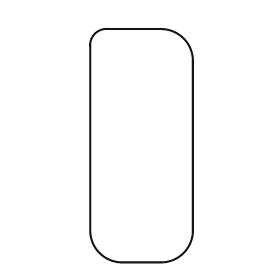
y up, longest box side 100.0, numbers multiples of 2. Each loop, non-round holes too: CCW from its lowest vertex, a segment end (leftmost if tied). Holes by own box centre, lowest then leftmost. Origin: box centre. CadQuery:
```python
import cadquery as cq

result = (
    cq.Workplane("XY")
    .moveTo(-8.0, -50.0)
    .lineTo(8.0, -50.0)
    .threePointArc((18.0, -46.0), (22.0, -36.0))
    .lineTo(22.0, 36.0)
    .threePointArc((18.0, 46.0), (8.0, 50.0))
    .lineTo(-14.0, 50.0)
    .threePointArc((-20.0, 48.0), (-22.0, 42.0))
    .lineTo(-22.0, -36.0)
    .threePointArc((-18.0, -46.0), (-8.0, -50.0))
    .close()
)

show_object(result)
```